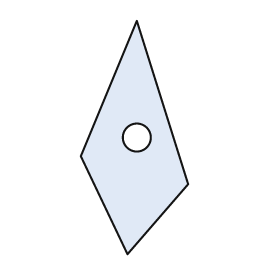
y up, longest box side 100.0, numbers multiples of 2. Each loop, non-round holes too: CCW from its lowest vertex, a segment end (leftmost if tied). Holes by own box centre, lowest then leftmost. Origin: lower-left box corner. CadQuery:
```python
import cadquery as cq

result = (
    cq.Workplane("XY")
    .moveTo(20.0, 0.0)
    .lineTo(46.0, 30.0)
    .lineTo(24.0, 100.0)
    .lineTo(0.0, 42.0)
    .close()
    .moveTo(24.0, 50.0)
    .circle(6.0)
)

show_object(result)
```